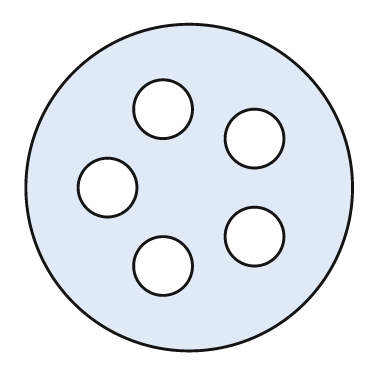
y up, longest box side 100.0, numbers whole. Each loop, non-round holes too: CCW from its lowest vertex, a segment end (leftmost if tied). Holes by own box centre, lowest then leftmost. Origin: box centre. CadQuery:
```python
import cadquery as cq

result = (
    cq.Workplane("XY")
    .moveTo(0.0, 0.0)
    .circle(50.0)
    .moveTo(-8.0, -24.0)
    .circle(9.0)
    .moveTo(20.0, -15.0)
    .circle(9.0)
    .moveTo(-25.0, 0.0)
    .circle(9.0)
    .moveTo(20.0, 15.0)
    .circle(9.0)
    .moveTo(-8.0, 24.0)
    .circle(9.0)
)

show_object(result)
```